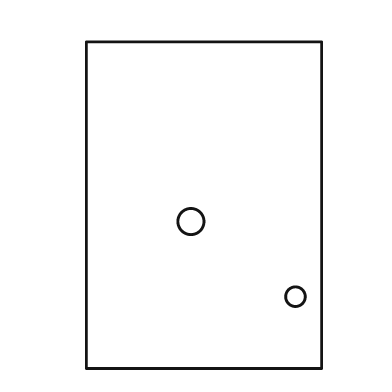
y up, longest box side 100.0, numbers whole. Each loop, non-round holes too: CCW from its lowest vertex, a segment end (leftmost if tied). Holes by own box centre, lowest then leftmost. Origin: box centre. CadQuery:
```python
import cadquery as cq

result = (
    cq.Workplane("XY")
    .moveTo(-36.0, -50.0)
    .lineTo(36.0, -50.0)
    .lineTo(36.0, 50.0)
    .lineTo(-36.0, 50.0)
    .close()
    .moveTo(28.0, -28.0)
    .circle(3.0)
    .moveTo(-4.0, -5.0)
    .circle(4.0)
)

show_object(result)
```